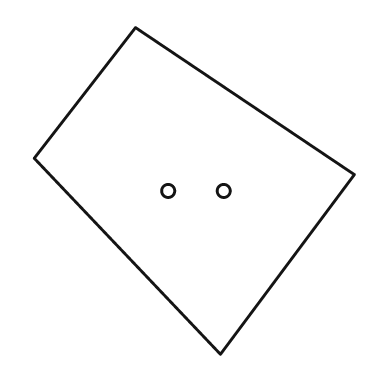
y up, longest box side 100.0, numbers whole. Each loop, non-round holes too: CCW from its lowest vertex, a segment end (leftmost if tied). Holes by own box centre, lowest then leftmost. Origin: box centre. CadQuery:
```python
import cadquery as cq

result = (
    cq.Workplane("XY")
    .moveTo(8.0, -50.0)
    .lineTo(49.0, 5.0)
    .lineTo(-18.0, 50.0)
    .lineTo(-49.0, 10.0)
    .close()
    .moveTo(-8.0, 0.0)
    .circle(2.0)
    .moveTo(9.0, 0.0)
    .circle(2.0)
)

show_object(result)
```